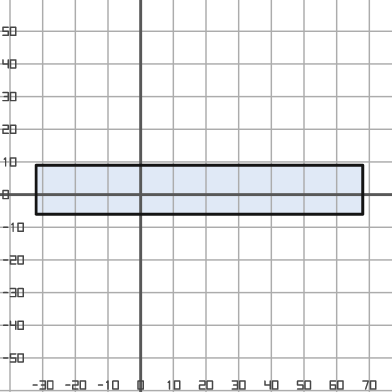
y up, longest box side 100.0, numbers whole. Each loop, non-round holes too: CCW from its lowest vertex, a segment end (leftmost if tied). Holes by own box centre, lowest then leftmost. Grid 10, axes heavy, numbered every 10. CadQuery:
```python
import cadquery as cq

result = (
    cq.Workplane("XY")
    .moveTo(-32.0, -6.0)
    .lineTo(68.0, -6.0)
    .lineTo(68.0, 9.0)
    .lineTo(-32.0, 9.0)
    .close()
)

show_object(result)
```